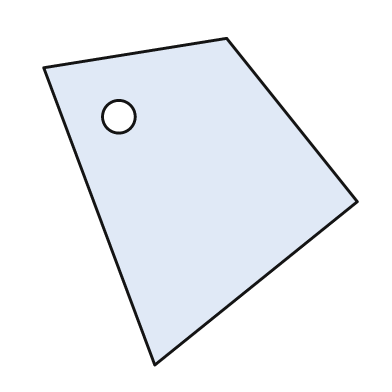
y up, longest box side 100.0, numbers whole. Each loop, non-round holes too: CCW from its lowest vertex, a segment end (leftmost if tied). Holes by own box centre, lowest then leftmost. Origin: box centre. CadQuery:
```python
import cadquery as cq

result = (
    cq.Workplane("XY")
    .moveTo(-14.0, -50.0)
    .lineTo(48.0, 0.0)
    .lineTo(8.0, 50.0)
    .lineTo(-48.0, 41.0)
    .close()
    .moveTo(-25.0, 26.0)
    .circle(5.0)
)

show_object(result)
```